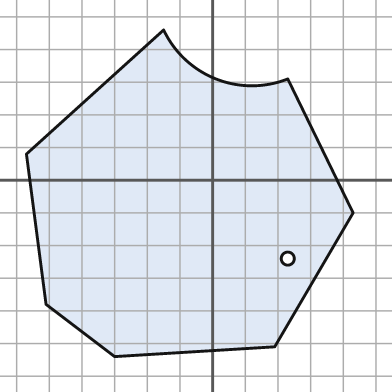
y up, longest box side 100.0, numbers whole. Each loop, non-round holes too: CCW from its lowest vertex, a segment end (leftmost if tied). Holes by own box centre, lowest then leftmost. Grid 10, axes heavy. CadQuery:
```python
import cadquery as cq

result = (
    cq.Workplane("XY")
    .moveTo(-30.0, -54.0)
    .lineTo(19.0, -51.0)
    .lineTo(43.0, -10.0)
    .lineTo(23.0, 31.0)
    .threePointArc((1.0, 31.0), (-15.0, 46.0))
    .lineTo(-57.0, 8.0)
    .lineTo(-51.0, -38.0)
    .close()
    .moveTo(23.0, -24.0)
    .circle(2.0)
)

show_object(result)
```